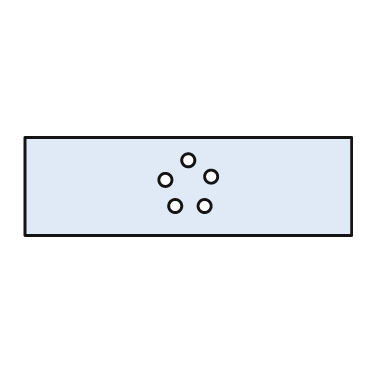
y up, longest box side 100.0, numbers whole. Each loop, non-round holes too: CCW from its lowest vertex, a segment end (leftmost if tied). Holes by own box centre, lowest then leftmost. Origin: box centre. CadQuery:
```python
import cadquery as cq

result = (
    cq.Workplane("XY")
    .moveTo(-50.0, -15.0)
    .lineTo(50.0, -15.0)
    .lineTo(50.0, 15.0)
    .lineTo(-50.0, 15.0)
    .close()
    .moveTo(-4.0, -6.0)
    .circle(2.0)
    .moveTo(5.0, -6.0)
    .circle(2.0)
    .moveTo(-7.0, 2.0)
    .circle(2.0)
    .moveTo(7.0, 3.0)
    .circle(2.0)
    .moveTo(0.0, 8.0)
    .circle(2.0)
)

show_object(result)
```